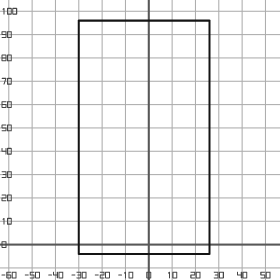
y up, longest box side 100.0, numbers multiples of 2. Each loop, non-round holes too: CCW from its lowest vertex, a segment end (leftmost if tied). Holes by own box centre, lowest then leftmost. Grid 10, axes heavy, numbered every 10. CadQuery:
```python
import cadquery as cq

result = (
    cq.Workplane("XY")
    .moveTo(-30.0, -4.0)
    .lineTo(26.0, -4.0)
    .lineTo(26.0, 96.0)
    .lineTo(-30.0, 96.0)
    .close()
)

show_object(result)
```